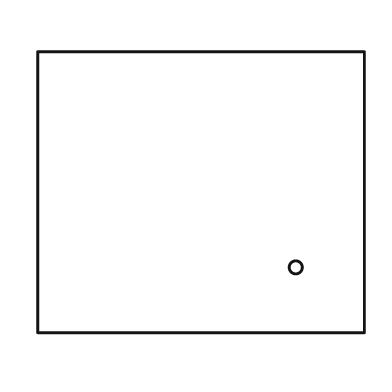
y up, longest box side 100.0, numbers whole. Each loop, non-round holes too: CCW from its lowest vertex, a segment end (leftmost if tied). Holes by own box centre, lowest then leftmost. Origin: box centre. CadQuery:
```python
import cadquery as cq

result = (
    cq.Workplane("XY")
    .moveTo(-50.0, -43.0)
    .lineTo(50.0, -43.0)
    .lineTo(50.0, 43.0)
    .lineTo(-50.0, 43.0)
    .close()
    .moveTo(29.0, -23.0)
    .circle(2.0)
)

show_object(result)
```